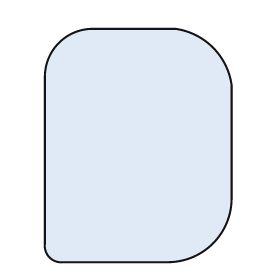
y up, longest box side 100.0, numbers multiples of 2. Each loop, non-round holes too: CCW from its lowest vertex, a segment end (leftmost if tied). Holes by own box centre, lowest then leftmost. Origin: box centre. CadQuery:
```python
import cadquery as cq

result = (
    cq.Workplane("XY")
    .moveTo(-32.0, -50.0)
    .lineTo(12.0, -50.0)
    .threePointArc((32.0, -42.0), (40.0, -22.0))
    .lineTo(40.0, 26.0)
    .threePointArc((32.0, 42.0), (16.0, 50.0))
    .lineTo(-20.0, 50.0)
    .threePointArc((-34.0, 44.0), (-40.0, 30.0))
    .lineTo(-40.0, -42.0)
    .threePointArc((-38.0, -48.0), (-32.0, -50.0))
    .close()
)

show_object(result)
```